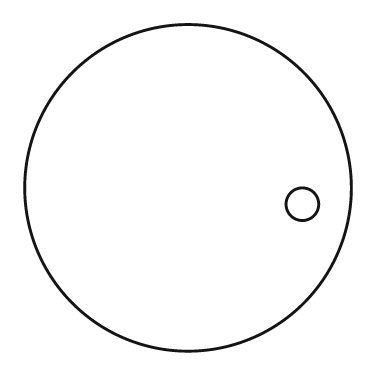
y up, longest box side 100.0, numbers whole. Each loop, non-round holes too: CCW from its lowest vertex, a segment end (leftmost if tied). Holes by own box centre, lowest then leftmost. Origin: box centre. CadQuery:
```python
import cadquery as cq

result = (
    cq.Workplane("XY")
    .moveTo(0.0, 0.0)
    .circle(50.0)
    .moveTo(35.0, -5.0)
    .circle(5.0)
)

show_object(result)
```